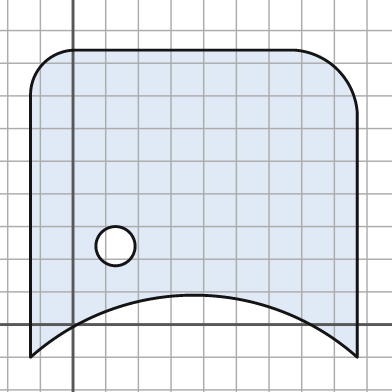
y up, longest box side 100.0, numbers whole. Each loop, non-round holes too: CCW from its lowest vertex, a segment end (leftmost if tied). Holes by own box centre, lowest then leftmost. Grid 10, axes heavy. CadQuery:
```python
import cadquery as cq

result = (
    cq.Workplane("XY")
    .moveTo(-13.0, -10.0)
    .threePointArc((37.0, 9.0), (87.0, -10.0))
    .lineTo(87.0, 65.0)
    .threePointArc((81.0, 78.0), (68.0, 84.0))
    .lineTo(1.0, 84.0)
    .threePointArc((-9.0, 80.0), (-13.0, 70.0))
    .close()
    .moveTo(13.0, 24.0)
    .circle(6.0)
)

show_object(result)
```